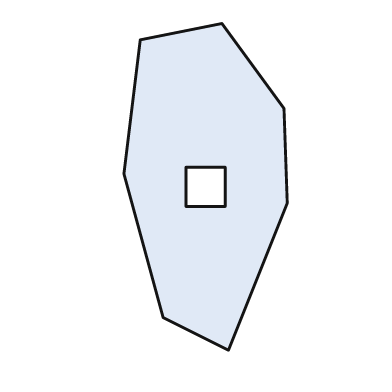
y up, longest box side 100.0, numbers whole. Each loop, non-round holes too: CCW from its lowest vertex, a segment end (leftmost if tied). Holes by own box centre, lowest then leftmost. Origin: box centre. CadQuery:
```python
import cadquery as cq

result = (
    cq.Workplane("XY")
    .moveTo(7.0, -50.0)
    .lineTo(25.0, -5.0)
    .lineTo(24.0, 24.0)
    .lineTo(5.0, 50.0)
    .lineTo(-20.0, 45.0)
    .lineTo(-25.0, 4.0)
    .lineTo(-13.0, -40.0)
    .close()
    .moveTo(-6.0, -6.0)
    .lineTo(6.0, -6.0)
    .lineTo(6.0, 6.0)
    .lineTo(-6.0, 6.0)
    .close()
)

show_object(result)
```